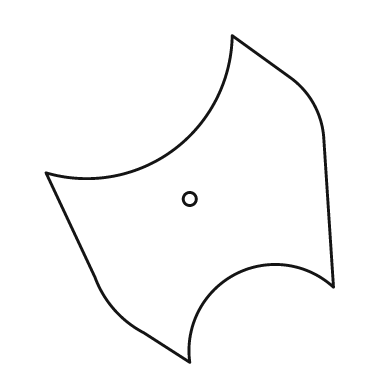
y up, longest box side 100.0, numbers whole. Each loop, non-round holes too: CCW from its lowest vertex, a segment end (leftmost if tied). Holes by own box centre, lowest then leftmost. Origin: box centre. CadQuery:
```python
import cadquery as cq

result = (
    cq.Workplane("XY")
    .moveTo(0.0, -50.0)
    .threePointArc((14.0, -23.0), (44.0, -27.0))
    .lineTo(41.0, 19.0)
    .threePointArc((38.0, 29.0), (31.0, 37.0))
    .lineTo(13.0, 50.0)
    .threePointArc((-5.0, 15.0), (-44.0, 8.0))
    .lineTo(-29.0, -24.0)
    .threePointArc((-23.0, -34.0), (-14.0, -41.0))
    .close()
    .moveTo(0.0, 0.0)
    .circle(2.0)
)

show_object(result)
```